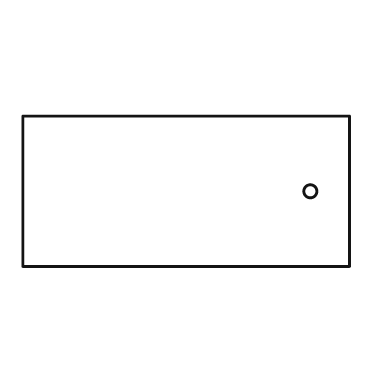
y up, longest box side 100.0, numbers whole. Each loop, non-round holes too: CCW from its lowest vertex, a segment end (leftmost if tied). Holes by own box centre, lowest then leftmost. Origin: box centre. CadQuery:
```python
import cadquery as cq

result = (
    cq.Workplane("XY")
    .moveTo(-50.0, -23.0)
    .lineTo(50.0, -23.0)
    .lineTo(50.0, 23.0)
    .lineTo(-50.0, 23.0)
    .close()
    .moveTo(38.0, 0.0)
    .circle(2.0)
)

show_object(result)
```